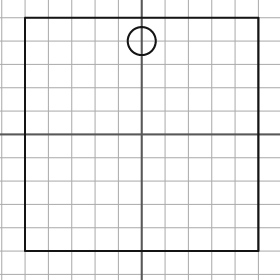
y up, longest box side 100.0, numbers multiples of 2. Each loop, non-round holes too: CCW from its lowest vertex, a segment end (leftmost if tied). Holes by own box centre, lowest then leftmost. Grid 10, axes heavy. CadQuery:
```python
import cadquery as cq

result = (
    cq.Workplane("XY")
    .moveTo(-50.0, -50.0)
    .lineTo(50.0, -50.0)
    .lineTo(50.0, 50.0)
    .lineTo(-50.0, 50.0)
    .close()
    .moveTo(0.0, 40.0)
    .circle(6.0)
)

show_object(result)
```